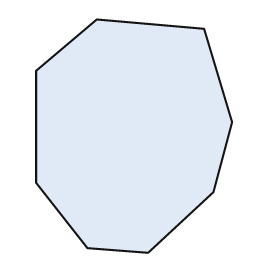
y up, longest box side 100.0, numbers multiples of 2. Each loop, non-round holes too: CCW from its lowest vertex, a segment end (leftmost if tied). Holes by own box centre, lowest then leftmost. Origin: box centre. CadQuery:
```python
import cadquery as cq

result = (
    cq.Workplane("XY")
    .moveTo(6.0, -50.0)
    .lineTo(34.0, -24.0)
    .lineTo(42.0, 6.0)
    .lineTo(30.0, 46.0)
    .lineTo(-16.0, 50.0)
    .lineTo(-42.0, 28.0)
    .lineTo(-42.0, -20.0)
    .lineTo(-20.0, -48.0)
    .close()
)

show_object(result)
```